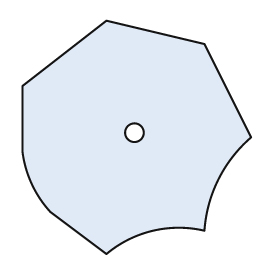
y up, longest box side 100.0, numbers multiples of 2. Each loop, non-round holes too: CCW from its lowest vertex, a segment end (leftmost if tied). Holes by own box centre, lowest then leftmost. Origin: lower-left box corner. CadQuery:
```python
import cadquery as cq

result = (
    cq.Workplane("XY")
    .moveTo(36.0, 0.0)
    .threePointArc((56.0, 10.0), (78.0, 10.0))
    .threePointArc((84.0, 32.0), (98.0, 50.0))
    .lineTo(78.0, 90.0)
    .lineTo(36.0, 100.0)
    .lineTo(0.0, 72.0)
    .lineTo(0.0, 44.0)
    .threePointArc((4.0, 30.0), (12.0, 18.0))
    .close()
    .moveTo(48.0, 52.0)
    .circle(4.0)
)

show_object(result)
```